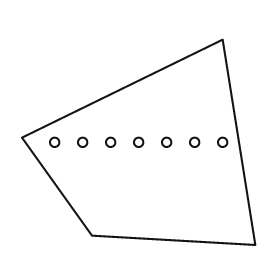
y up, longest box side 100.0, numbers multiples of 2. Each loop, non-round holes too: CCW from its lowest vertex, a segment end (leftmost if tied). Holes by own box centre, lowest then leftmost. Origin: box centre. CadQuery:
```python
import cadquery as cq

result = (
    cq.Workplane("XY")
    .moveTo(50.0, -44.0)
    .lineTo(36.0, 44.0)
    .lineTo(-50.0, 2.0)
    .lineTo(-20.0, -40.0)
    .close()
    .moveTo(-36.0, 0.0)
    .circle(2.0)
    .moveTo(-24.0, 0.0)
    .circle(2.0)
    .moveTo(-12.0, 0.0)
    .circle(2.0)
    .moveTo(0.0, 0.0)
    .circle(2.0)
    .moveTo(12.0, 0.0)
    .circle(2.0)
    .moveTo(24.0, 0.0)
    .circle(2.0)
    .moveTo(36.0, 0.0)
    .circle(2.0)
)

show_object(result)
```